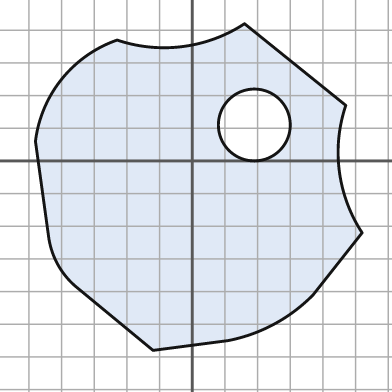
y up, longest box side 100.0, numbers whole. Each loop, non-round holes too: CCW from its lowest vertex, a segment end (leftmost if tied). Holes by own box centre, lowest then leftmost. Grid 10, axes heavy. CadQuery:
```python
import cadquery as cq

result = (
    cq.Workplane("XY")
    .moveTo(-12.0, -58.0)
    .lineTo(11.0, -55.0)
    .threePointArc((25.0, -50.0), (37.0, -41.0))
    .lineTo(52.0, -22.0)
    .threePointArc((45.0, -3.0), (47.0, 17.0))
    .lineTo(16.0, 42.0)
    .threePointArc((-3.0, 35.0), (-23.0, 37.0))
    .threePointArc((-40.0, 25.0), (-48.0, 6.0))
    .lineTo(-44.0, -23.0)
    .threePointArc((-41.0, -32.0), (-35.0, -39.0))
    .close()
    .moveTo(19.0, 11.0)
    .circle(11.0)
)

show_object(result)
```